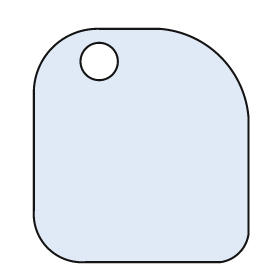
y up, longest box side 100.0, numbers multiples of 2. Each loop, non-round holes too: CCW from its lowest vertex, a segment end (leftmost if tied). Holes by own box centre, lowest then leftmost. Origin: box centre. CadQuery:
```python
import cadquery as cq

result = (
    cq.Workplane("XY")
    .moveTo(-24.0, -50.0)
    .lineTo(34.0, -50.0)
    .threePointArc((42.0, -46.0), (46.0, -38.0))
    .lineTo(46.0, 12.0)
    .threePointArc((34.0, 38.0), (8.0, 50.0))
    .lineTo(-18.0, 50.0)
    .threePointArc((-38.0, 42.0), (-46.0, 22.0))
    .lineTo(-46.0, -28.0)
    .threePointArc((-40.0, -44.0), (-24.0, -50.0))
    .close()
    .moveTo(-18.0, 36.0)
    .circle(8.0)
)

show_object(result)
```